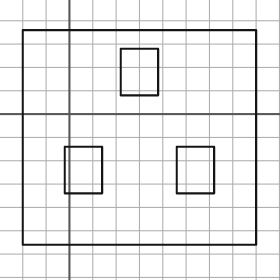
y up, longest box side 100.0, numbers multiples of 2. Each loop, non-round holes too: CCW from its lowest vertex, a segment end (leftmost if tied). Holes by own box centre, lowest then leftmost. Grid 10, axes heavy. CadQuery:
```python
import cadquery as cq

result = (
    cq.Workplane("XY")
    .moveTo(-20.0, -56.0)
    .lineTo(80.0, -56.0)
    .lineTo(80.0, 36.0)
    .lineTo(-20.0, 36.0)
    .close()
    .moveTo(-2.0, -34.0)
    .lineTo(14.0, -34.0)
    .lineTo(14.0, -14.0)
    .lineTo(-2.0, -14.0)
    .close()
    .moveTo(46.0, -34.0)
    .lineTo(62.0, -34.0)
    .lineTo(62.0, -14.0)
    .lineTo(46.0, -14.0)
    .close()
    .moveTo(22.0, 8.0)
    .lineTo(38.0, 8.0)
    .lineTo(38.0, 28.0)
    .lineTo(22.0, 28.0)
    .close()
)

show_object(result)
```